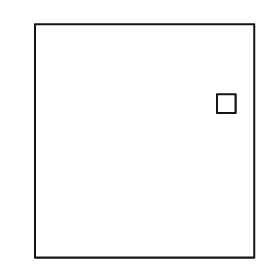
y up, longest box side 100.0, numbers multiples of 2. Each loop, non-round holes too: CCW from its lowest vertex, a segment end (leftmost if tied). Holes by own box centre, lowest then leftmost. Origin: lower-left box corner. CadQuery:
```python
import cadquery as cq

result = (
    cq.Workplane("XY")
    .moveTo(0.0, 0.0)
    .lineTo(94.0, 0.0)
    .lineTo(94.0, 100.0)
    .lineTo(0.0, 100.0)
    .close()
    .moveTo(78.0, 62.0)
    .lineTo(86.0, 62.0)
    .lineTo(86.0, 70.0)
    .lineTo(78.0, 70.0)
    .close()
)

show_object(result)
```